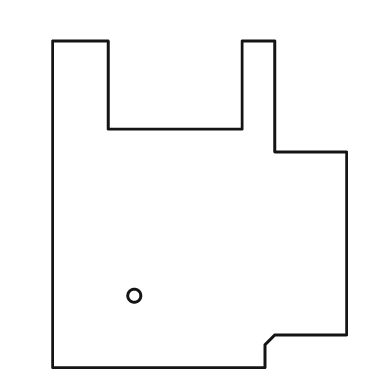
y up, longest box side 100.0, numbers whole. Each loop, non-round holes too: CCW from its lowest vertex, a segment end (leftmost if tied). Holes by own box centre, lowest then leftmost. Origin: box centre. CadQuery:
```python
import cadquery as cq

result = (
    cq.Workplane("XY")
    .moveTo(-45.0, -50.0)
    .lineTo(20.0, -50.0)
    .lineTo(20.0, -43.0)
    .lineTo(23.0, -40.0)
    .lineTo(45.0, -40.0)
    .lineTo(45.0, 16.0)
    .lineTo(23.0, 16.0)
    .lineTo(23.0, 50.0)
    .lineTo(13.0, 50.0)
    .lineTo(13.0, 23.0)
    .lineTo(-28.0, 23.0)
    .lineTo(-28.0, 50.0)
    .lineTo(-45.0, 50.0)
    .close()
    .moveTo(-20.0, -28.0)
    .circle(2.0)
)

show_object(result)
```